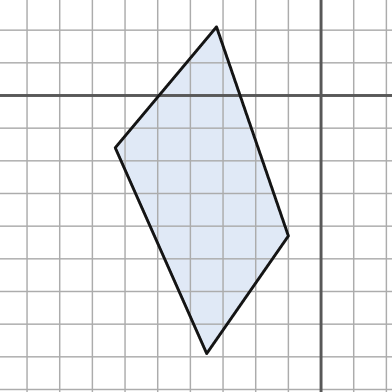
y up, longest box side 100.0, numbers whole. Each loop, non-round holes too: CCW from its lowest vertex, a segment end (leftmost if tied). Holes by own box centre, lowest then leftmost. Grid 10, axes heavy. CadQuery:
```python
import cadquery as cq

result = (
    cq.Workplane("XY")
    .moveTo(-35.0, -79.0)
    .lineTo(-10.0, -43.0)
    .lineTo(-32.0, 21.0)
    .lineTo(-63.0, -16.0)
    .close()
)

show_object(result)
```